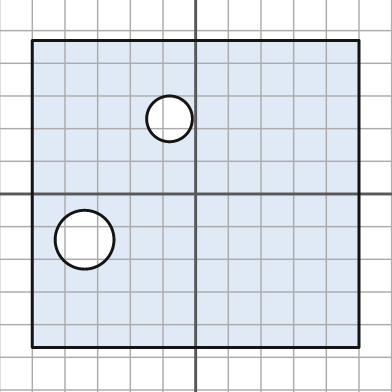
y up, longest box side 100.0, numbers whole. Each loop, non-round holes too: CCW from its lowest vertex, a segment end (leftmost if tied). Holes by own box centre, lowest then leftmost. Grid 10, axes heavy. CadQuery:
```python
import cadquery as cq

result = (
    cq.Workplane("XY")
    .moveTo(-50.0, -47.0)
    .lineTo(50.0, -47.0)
    .lineTo(50.0, 47.0)
    .lineTo(-50.0, 47.0)
    .close()
    .moveTo(-34.0, -14.0)
    .circle(9.0)
    .moveTo(-8.0, 23.0)
    .circle(7.0)
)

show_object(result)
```